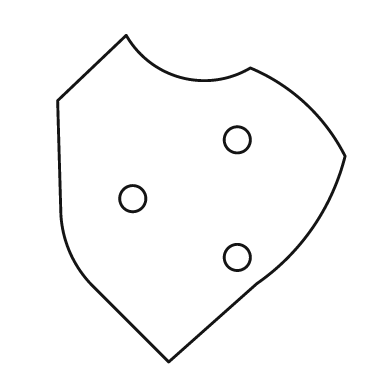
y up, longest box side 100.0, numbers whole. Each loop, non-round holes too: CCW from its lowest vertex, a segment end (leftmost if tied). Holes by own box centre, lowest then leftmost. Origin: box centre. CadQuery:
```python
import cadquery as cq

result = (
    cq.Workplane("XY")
    .moveTo(-10.0, -50.0)
    .lineTo(17.0, -26.0)
    .threePointArc((34.0, -9.0), (44.0, 13.0))
    .threePointArc((32.0, 29.0), (15.0, 40.0))
    .threePointArc((-6.0, 37.0), (-23.0, 50.0))
    .lineTo(-44.0, 30.0)
    .lineTo(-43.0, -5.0)
    .threePointArc((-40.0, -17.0), (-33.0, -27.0))
    .close()
    .moveTo(11.0, -18.0)
    .circle(4.0)
    .moveTo(-21.0, 0.0)
    .circle(4.0)
    .moveTo(11.0, 18.0)
    .circle(4.0)
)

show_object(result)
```